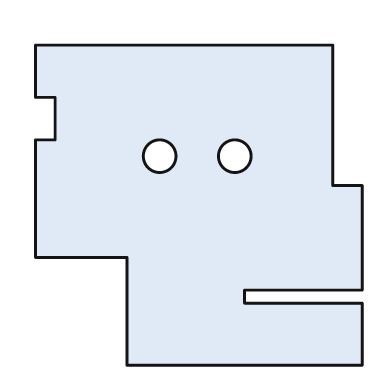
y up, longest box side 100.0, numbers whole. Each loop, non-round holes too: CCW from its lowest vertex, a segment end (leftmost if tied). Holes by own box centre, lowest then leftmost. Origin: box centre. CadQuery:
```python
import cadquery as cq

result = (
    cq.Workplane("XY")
    .moveTo(-22.0, -49.0)
    .lineTo(50.0, -49.0)
    .lineTo(50.0, -30.0)
    .lineTo(14.0, -30.0)
    .lineTo(14.0, -26.0)
    .lineTo(50.0, -26.0)
    .lineTo(50.0, 6.0)
    .lineTo(41.0, 6.0)
    .lineTo(41.0, 49.0)
    .lineTo(-50.0, 49.0)
    .lineTo(-50.0, 33.0)
    .lineTo(-44.0, 33.0)
    .lineTo(-44.0, 20.0)
    .lineTo(-50.0, 20.0)
    .lineTo(-50.0, -16.0)
    .lineTo(-22.0, -16.0)
    .close()
    .moveTo(-12.0, 15.0)
    .circle(5.0)
    .moveTo(11.0, 15.0)
    .circle(5.0)
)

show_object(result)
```